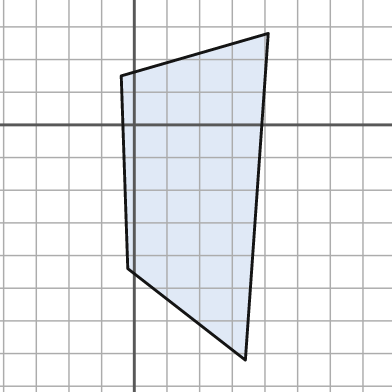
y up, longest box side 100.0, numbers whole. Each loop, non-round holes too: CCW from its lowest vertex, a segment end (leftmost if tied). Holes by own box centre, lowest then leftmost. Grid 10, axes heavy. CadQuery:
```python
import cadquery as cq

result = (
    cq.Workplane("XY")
    .moveTo(34.0, -72.0)
    .lineTo(41.0, 28.0)
    .lineTo(-4.0, 15.0)
    .lineTo(-2.0, -44.0)
    .close()
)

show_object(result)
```